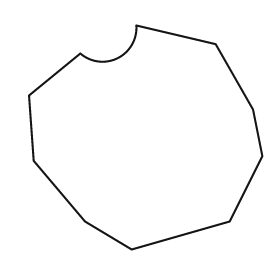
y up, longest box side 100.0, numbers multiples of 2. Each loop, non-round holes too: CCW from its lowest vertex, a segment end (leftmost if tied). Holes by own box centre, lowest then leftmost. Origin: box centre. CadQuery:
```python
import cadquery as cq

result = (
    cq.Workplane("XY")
    .moveTo(-6.0, -48.0)
    .lineTo(36.0, -36.0)
    .lineTo(50.0, -8.0)
    .lineTo(46.0, 12.0)
    .lineTo(30.0, 40.0)
    .lineTo(-4.0, 48.0)
    .threePointArc((-12.0, 34.0), (-28.0, 36.0))
    .lineTo(-50.0, 18.0)
    .lineTo(-48.0, -10.0)
    .lineTo(-26.0, -36.0)
    .close()
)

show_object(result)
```